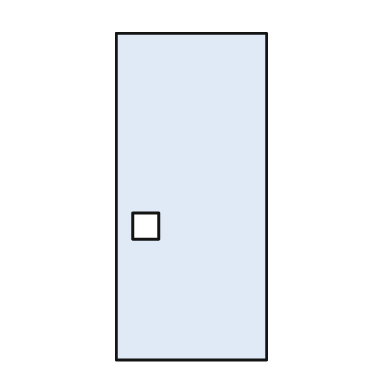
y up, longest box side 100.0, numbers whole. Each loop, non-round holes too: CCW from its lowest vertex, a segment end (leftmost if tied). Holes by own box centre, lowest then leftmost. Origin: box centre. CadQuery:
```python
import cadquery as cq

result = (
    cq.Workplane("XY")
    .moveTo(-23.0, -50.0)
    .lineTo(23.0, -50.0)
    .lineTo(23.0, 50.0)
    .lineTo(-23.0, 50.0)
    .close()
    .moveTo(-18.0, -13.0)
    .lineTo(-10.0, -13.0)
    .lineTo(-10.0, -5.0)
    .lineTo(-18.0, -5.0)
    .close()
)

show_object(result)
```